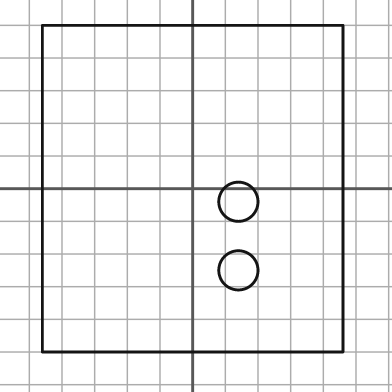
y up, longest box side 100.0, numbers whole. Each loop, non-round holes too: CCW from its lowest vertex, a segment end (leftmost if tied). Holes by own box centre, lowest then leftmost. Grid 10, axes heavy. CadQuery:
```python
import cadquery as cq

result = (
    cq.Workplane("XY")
    .moveTo(-46.0, -50.0)
    .lineTo(46.0, -50.0)
    .lineTo(46.0, 50.0)
    .lineTo(-46.0, 50.0)
    .close()
    .moveTo(14.0, -25.0)
    .circle(6.0)
    .moveTo(14.0, -4.0)
    .circle(6.0)
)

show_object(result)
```